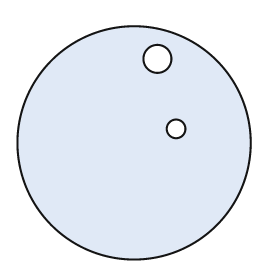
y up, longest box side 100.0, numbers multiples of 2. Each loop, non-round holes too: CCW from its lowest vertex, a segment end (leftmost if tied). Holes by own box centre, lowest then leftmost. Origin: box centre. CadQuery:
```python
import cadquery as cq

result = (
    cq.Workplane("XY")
    .moveTo(0.0, 0.0)
    .circle(50.0)
    .moveTo(18.0, 6.0)
    .circle(4.0)
    .moveTo(10.0, 36.0)
    .circle(6.0)
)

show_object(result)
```